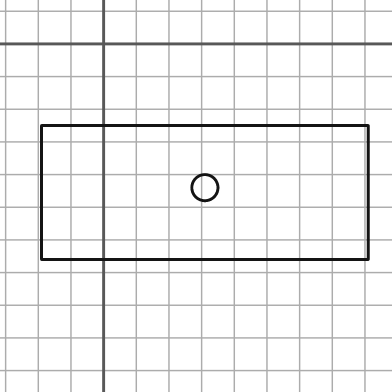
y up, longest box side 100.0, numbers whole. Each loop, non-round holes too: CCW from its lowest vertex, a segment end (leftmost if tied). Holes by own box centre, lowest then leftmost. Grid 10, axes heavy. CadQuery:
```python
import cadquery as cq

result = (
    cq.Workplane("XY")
    .moveTo(-19.0, -66.0)
    .lineTo(81.0, -66.0)
    .lineTo(81.0, -25.0)
    .lineTo(-19.0, -25.0)
    .close()
    .moveTo(31.0, -44.0)
    .circle(4.0)
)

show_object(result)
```